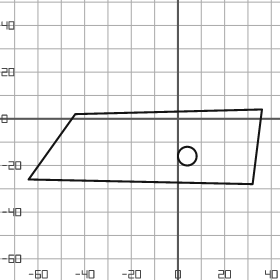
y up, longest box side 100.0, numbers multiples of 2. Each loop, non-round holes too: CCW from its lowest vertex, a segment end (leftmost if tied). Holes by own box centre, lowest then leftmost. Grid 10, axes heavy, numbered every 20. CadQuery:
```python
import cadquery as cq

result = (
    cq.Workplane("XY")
    .moveTo(32.0, -28.0)
    .lineTo(36.0, 4.0)
    .lineTo(-44.0, 2.0)
    .lineTo(-64.0, -26.0)
    .close()
    .moveTo(4.0, -16.0)
    .circle(4.0)
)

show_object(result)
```